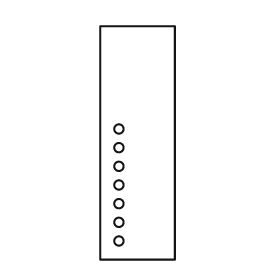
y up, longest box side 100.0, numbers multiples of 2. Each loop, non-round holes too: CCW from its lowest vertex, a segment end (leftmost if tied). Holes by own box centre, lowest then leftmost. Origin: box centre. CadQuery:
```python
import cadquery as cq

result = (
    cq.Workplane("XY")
    .moveTo(-16.0, -50.0)
    .lineTo(16.0, -50.0)
    .lineTo(16.0, 50.0)
    .lineTo(-16.0, 50.0)
    .close()
    .moveTo(-8.0, -42.0)
    .circle(2.0)
    .moveTo(-8.0, -34.0)
    .circle(2.0)
    .moveTo(-8.0, -26.0)
    .circle(2.0)
    .moveTo(-8.0, -18.0)
    .circle(2.0)
    .moveTo(-8.0, -10.0)
    .circle(2.0)
    .moveTo(-8.0, -2.0)
    .circle(2.0)
    .moveTo(-8.0, 6.0)
    .circle(2.0)
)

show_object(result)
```